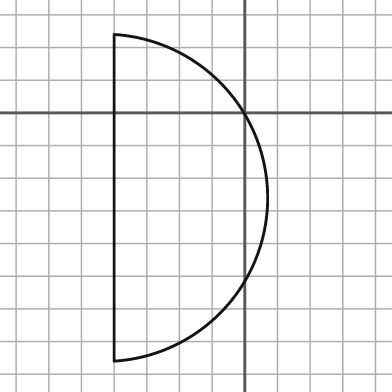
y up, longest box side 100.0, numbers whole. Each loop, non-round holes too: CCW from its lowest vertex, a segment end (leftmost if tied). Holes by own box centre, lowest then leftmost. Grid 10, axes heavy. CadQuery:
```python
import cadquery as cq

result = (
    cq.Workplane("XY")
    .moveTo(-40.0, -76.0)
    .threePointArc((7.0, -26.0), (-40.0, 24.0))
    .close()
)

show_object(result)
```